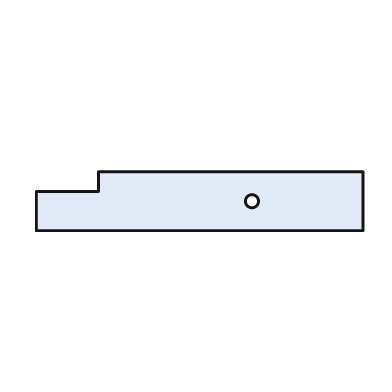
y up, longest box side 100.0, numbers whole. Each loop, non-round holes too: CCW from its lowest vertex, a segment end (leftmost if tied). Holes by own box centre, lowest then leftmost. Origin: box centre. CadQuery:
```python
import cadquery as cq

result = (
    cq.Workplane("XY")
    .moveTo(-50.0, -9.0)
    .lineTo(50.0, -9.0)
    .lineTo(50.0, 9.0)
    .lineTo(-31.0, 9.0)
    .lineTo(-31.0, 3.0)
    .lineTo(-50.0, 3.0)
    .close()
    .moveTo(16.0, 0.0)
    .circle(2.0)
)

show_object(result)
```